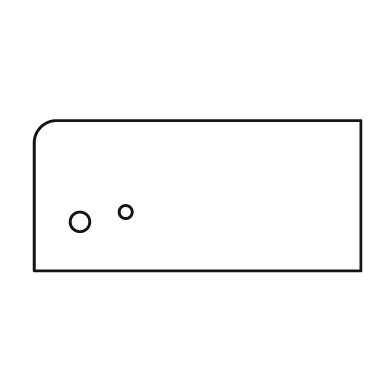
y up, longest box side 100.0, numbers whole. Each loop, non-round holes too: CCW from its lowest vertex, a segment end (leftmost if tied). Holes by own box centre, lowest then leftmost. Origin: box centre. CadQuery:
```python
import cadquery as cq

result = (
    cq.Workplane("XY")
    .moveTo(-50.0, -23.0)
    .lineTo(50.0, -23.0)
    .lineTo(50.0, 23.0)
    .lineTo(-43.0, 23.0)
    .threePointArc((-48.0, 21.0), (-50.0, 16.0))
    .close()
    .moveTo(-36.0, -8.0)
    .circle(3.0)
    .moveTo(-22.0, -5.0)
    .circle(2.0)
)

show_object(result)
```